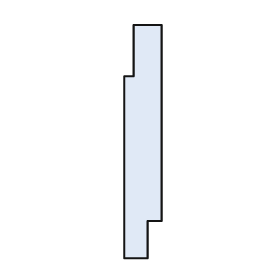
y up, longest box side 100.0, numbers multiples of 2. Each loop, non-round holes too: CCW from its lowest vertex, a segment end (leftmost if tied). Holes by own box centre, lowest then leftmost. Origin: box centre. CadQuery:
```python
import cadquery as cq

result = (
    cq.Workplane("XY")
    .moveTo(-8.0, -50.0)
    .lineTo(2.0, -50.0)
    .lineTo(2.0, -34.0)
    .lineTo(8.0, -34.0)
    .lineTo(8.0, 50.0)
    .lineTo(-4.0, 50.0)
    .lineTo(-4.0, 28.0)
    .lineTo(-8.0, 28.0)
    .close()
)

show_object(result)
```